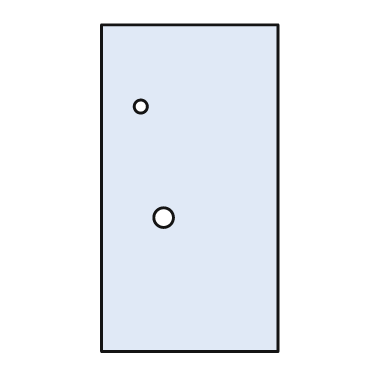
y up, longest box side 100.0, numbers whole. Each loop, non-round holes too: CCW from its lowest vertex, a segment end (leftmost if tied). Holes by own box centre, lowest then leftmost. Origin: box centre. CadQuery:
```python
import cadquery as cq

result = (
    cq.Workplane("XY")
    .moveTo(-27.0, -50.0)
    .lineTo(27.0, -50.0)
    .lineTo(27.0, 50.0)
    .lineTo(-27.0, 50.0)
    .close()
    .moveTo(-8.0, -9.0)
    .circle(3.0)
    .moveTo(-15.0, 25.0)
    .circle(2.0)
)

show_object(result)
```